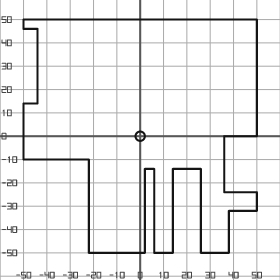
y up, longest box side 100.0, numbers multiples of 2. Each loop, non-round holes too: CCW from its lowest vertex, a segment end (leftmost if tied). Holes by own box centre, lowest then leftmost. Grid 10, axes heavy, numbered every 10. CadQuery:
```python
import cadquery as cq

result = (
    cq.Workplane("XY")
    .moveTo(-22.0, -50.0)
    .lineTo(2.0, -50.0)
    .lineTo(2.0, -14.0)
    .lineTo(6.0, -14.0)
    .lineTo(6.0, -50.0)
    .lineTo(14.0, -50.0)
    .lineTo(14.0, -14.0)
    .lineTo(26.0, -14.0)
    .lineTo(26.0, -50.0)
    .lineTo(38.0, -50.0)
    .lineTo(38.0, -32.0)
    .lineTo(50.0, -32.0)
    .lineTo(50.0, -24.0)
    .lineTo(36.0, -24.0)
    .lineTo(36.0, 0.0)
    .lineTo(50.0, 0.0)
    .lineTo(50.0, 50.0)
    .lineTo(-50.0, 50.0)
    .lineTo(-50.0, 46.0)
    .lineTo(-44.0, 46.0)
    .lineTo(-44.0, 14.0)
    .lineTo(-50.0, 14.0)
    .lineTo(-50.0, -10.0)
    .lineTo(-22.0, -10.0)
    .close()
    .moveTo(0.0, 0.0)
    .circle(2.0)
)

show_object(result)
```